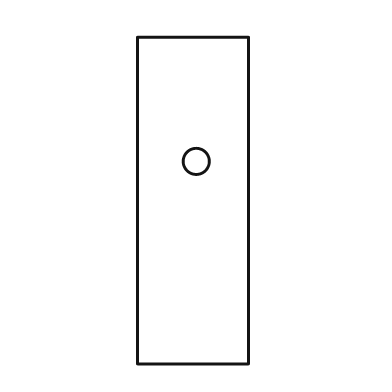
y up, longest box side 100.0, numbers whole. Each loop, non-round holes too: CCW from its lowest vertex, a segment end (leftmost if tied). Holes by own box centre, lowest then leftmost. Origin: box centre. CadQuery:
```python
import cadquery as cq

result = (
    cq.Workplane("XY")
    .moveTo(-17.0, -50.0)
    .lineTo(17.0, -50.0)
    .lineTo(17.0, 50.0)
    .lineTo(-17.0, 50.0)
    .close()
    .moveTo(1.0, 12.0)
    .circle(4.0)
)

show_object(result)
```